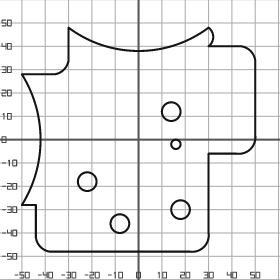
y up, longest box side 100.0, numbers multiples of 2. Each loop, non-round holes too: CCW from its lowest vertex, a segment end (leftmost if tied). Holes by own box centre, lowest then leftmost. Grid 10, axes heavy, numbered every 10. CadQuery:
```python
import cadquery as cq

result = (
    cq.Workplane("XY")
    .moveTo(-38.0, -48.0)
    .lineTo(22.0, -48.0)
    .threePointArc((28.0, -46.0), (30.0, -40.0))
    .lineTo(30.0, -6.0)
    .lineTo(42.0, -6.0)
    .threePointArc((48.0, -4.0), (50.0, 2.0))
    .lineTo(50.0, 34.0)
    .threePointArc((48.0, 38.0), (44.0, 40.0))
    .lineTo(30.0, 40.0)
    .threePointArc((32.0, 44.0), (30.0, 48.0))
    .threePointArc((0.0, 38.0), (-30.0, 48.0))
    .lineTo(-30.0, 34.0)
    .threePointArc((-32.0, 30.0), (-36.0, 28.0))
    .lineTo(-50.0, 28.0)
    .threePointArc((-42.0, 0.0), (-50.0, -28.0))
    .lineTo(-44.0, -28.0)
    .lineTo(-44.0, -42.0)
    .threePointArc((-42.0, -46.0), (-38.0, -48.0))
    .close()
    .moveTo(-8.0, -36.0)
    .circle(4.0)
    .moveTo(18.0, -30.0)
    .circle(4.0)
    .moveTo(-22.0, -18.0)
    .circle(4.0)
    .moveTo(16.0, -2.0)
    .circle(2.0)
    .moveTo(14.0, 12.0)
    .circle(4.0)
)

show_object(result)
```